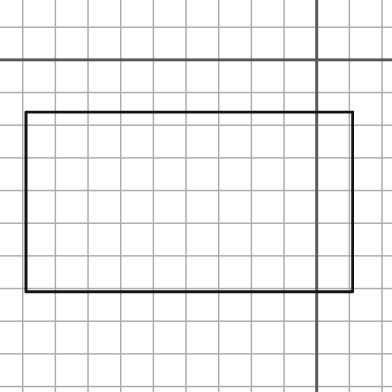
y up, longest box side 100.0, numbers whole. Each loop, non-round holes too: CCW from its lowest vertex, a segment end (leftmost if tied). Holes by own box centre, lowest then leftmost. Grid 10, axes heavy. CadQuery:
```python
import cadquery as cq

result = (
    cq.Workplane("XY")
    .moveTo(-89.0, -71.0)
    .lineTo(11.0, -71.0)
    .lineTo(11.0, -16.0)
    .lineTo(-89.0, -16.0)
    .close()
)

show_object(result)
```